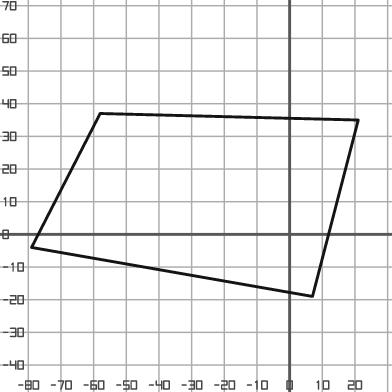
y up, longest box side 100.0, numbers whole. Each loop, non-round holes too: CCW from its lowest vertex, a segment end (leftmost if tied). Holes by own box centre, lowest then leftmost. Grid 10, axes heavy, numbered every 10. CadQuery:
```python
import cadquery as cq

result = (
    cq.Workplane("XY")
    .moveTo(7.0, -19.0)
    .lineTo(21.0, 35.0)
    .lineTo(-58.0, 37.0)
    .lineTo(-79.0, -4.0)
    .close()
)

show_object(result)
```